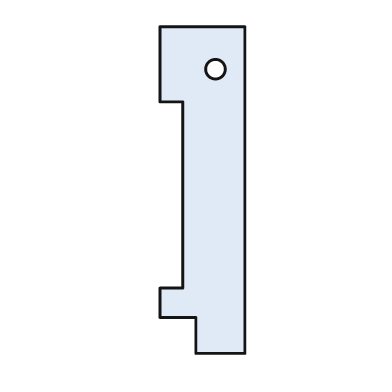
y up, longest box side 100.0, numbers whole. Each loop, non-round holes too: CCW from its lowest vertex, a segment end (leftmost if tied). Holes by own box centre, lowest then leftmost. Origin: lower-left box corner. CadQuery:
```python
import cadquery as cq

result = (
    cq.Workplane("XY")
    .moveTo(11.0, 0.0)
    .lineTo(26.0, 0.0)
    .lineTo(26.0, 100.0)
    .lineTo(0.0, 100.0)
    .lineTo(0.0, 77.0)
    .lineTo(7.0, 77.0)
    .lineTo(7.0, 20.0)
    .lineTo(0.0, 20.0)
    .lineTo(0.0, 11.0)
    .lineTo(11.0, 11.0)
    .close()
    .moveTo(17.0, 87.0)
    .circle(3.0)
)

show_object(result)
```